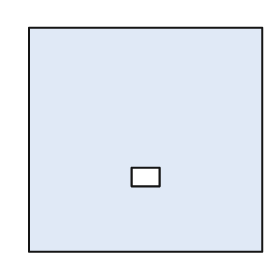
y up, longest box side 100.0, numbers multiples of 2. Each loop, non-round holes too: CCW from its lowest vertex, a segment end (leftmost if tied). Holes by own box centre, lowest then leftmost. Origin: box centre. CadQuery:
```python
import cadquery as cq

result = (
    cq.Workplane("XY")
    .moveTo(-50.0, -48.0)
    .lineTo(50.0, -48.0)
    .lineTo(50.0, 48.0)
    .lineTo(-50.0, 48.0)
    .close()
    .moveTo(-6.0, -20.0)
    .lineTo(6.0, -20.0)
    .lineTo(6.0, -12.0)
    .lineTo(-6.0, -12.0)
    .close()
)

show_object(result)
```